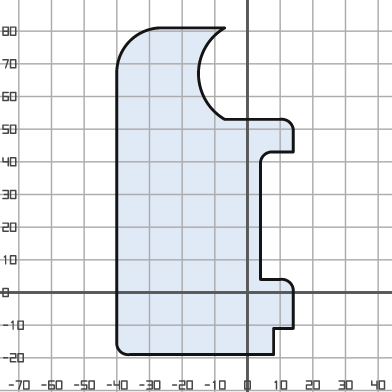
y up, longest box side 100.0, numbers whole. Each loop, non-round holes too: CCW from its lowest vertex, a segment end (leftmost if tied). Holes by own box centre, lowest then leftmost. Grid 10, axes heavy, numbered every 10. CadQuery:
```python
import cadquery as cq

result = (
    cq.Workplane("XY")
    .moveTo(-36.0, -19.0)
    .lineTo(8.0, -19.0)
    .lineTo(8.0, -11.0)
    .lineTo(14.0, -11.0)
    .lineTo(14.0, 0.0)
    .threePointArc((13.0, 3.0), (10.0, 4.0))
    .lineTo(4.0, 4.0)
    .lineTo(4.0, 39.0)
    .threePointArc((5.0, 42.0), (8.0, 43.0))
    .lineTo(14.0, 43.0)
    .lineTo(14.0, 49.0)
    .threePointArc((13.0, 52.0), (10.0, 53.0))
    .lineTo(-7.0, 53.0)
    .threePointArc((-15.0, 67.0), (-7.0, 81.0))
    .lineTo(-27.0, 81.0)
    .threePointArc((-36.0, 77.0), (-40.0, 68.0))
    .lineTo(-40.0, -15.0)
    .threePointArc((-39.0, -18.0), (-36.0, -19.0))
    .close()
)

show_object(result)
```